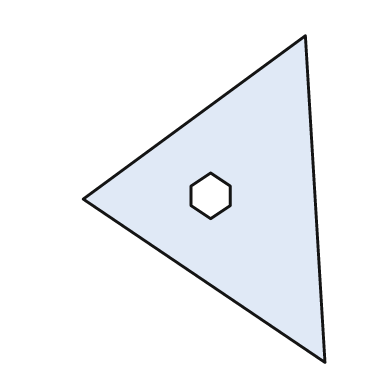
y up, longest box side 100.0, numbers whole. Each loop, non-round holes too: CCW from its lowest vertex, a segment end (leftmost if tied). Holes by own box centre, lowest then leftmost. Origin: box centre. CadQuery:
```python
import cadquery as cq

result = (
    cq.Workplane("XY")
    .moveTo(37.0, -50.0)
    .lineTo(31.0, 50.0)
    .lineTo(-37.0, 0.0)
    .close()
    .moveTo(2.0, -6.0)
    .lineTo(8.0, -2.0)
    .lineTo(8.0, 4.0)
    .lineTo(2.0, 8.0)
    .lineTo(-4.0, 4.0)
    .lineTo(-4.0, -2.0)
    .close()
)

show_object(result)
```